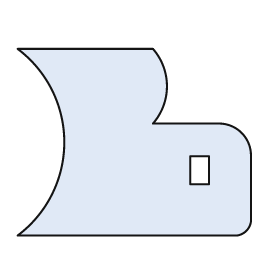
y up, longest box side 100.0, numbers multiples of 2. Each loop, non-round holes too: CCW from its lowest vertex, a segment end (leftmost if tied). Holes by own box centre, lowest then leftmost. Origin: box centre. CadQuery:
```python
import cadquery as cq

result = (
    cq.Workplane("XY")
    .moveTo(-50.0, -40.0)
    .lineTo(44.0, -40.0)
    .threePointArc((48.0, -38.0), (50.0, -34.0))
    .lineTo(50.0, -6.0)
    .threePointArc((46.0, 4.0), (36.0, 8.0))
    .lineTo(8.0, 8.0)
    .threePointArc((14.0, 24.0), (8.0, 40.0))
    .lineTo(-50.0, 40.0)
    .threePointArc((-30.0, 0.0), (-50.0, -40.0))
    .close()
    .moveTo(24.0, -18.0)
    .lineTo(32.0, -18.0)
    .lineTo(32.0, -6.0)
    .lineTo(24.0, -6.0)
    .close()
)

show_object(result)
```